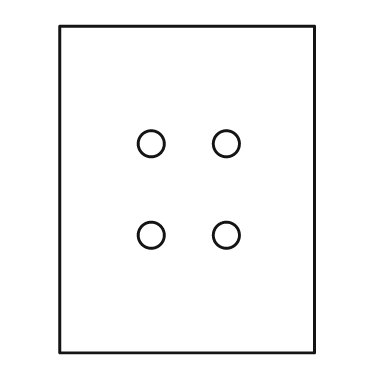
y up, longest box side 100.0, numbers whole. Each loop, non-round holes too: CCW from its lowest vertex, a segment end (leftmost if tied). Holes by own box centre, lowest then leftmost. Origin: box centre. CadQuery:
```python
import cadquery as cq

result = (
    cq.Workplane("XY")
    .moveTo(-39.0, -50.0)
    .lineTo(39.0, -50.0)
    .lineTo(39.0, 50.0)
    .lineTo(-39.0, 50.0)
    .close()
    .moveTo(-11.0, -14.0)
    .circle(4.0)
    .moveTo(12.0, -14.0)
    .circle(4.0)
    .moveTo(-11.0, 14.0)
    .circle(4.0)
    .moveTo(12.0, 14.0)
    .circle(4.0)
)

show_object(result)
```